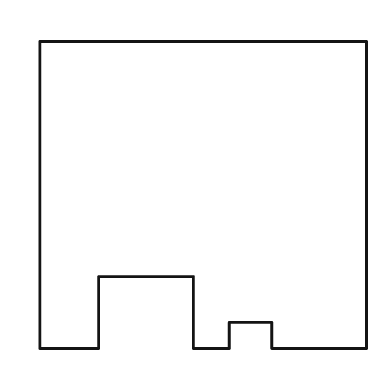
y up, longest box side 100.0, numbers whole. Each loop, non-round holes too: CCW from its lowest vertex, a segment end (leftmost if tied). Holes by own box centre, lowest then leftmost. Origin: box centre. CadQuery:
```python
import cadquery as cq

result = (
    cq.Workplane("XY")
    .moveTo(-50.0, -47.0)
    .lineTo(-32.0, -47.0)
    .lineTo(-32.0, -25.0)
    .lineTo(-3.0, -25.0)
    .lineTo(-3.0, -47.0)
    .lineTo(8.0, -47.0)
    .lineTo(8.0, -39.0)
    .lineTo(21.0, -39.0)
    .lineTo(21.0, -47.0)
    .lineTo(50.0, -47.0)
    .lineTo(50.0, 47.0)
    .lineTo(-50.0, 47.0)
    .close()
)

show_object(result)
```